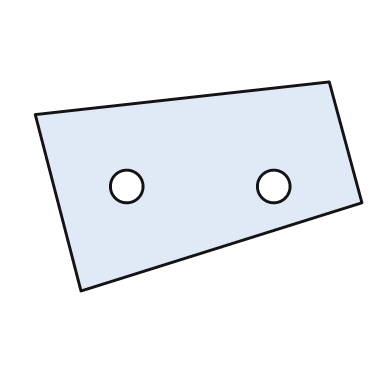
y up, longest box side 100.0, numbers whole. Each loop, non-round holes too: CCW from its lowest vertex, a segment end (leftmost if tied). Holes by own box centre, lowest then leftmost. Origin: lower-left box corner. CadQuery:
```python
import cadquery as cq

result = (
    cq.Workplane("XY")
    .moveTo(14.0, 0.0)
    .lineTo(100.0, 27.0)
    .lineTo(90.0, 64.0)
    .lineTo(0.0, 54.0)
    .close()
    .moveTo(28.0, 32.0)
    .circle(5.0)
    .moveTo(73.0, 32.0)
    .circle(5.0)
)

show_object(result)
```